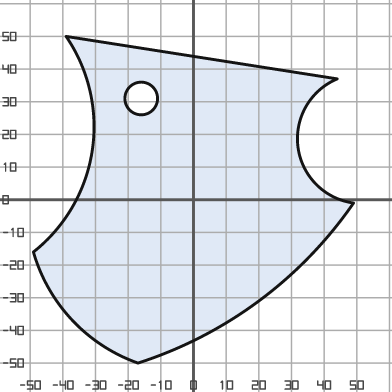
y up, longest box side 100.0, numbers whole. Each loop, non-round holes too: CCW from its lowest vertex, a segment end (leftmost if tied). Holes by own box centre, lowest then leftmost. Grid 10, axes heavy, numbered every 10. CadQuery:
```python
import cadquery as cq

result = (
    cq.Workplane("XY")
    .moveTo(-17.0, -50.0)
    .threePointArc((20.0, -31.0), (49.0, -1.0))
    .threePointArc((32.0, 16.0), (44.0, 37.0))
    .lineTo(-39.0, 50.0)
    .threePointArc((-31.0, 15.0), (-49.0, -16.0))
    .threePointArc((-37.0, -37.0), (-17.0, -50.0))
    .close()
    .moveTo(-16.0, 31.0)
    .circle(5.0)
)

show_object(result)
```